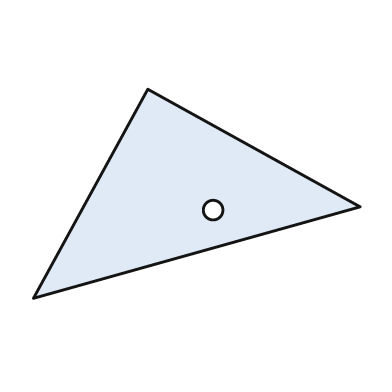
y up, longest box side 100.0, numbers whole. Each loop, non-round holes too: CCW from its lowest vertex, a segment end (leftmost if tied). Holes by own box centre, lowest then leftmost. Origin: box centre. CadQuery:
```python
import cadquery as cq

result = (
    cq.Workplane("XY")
    .moveTo(-50.0, -32.0)
    .lineTo(50.0, -4.0)
    .lineTo(-15.0, 32.0)
    .close()
    .moveTo(5.0, -5.0)
    .circle(3.0)
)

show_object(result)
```